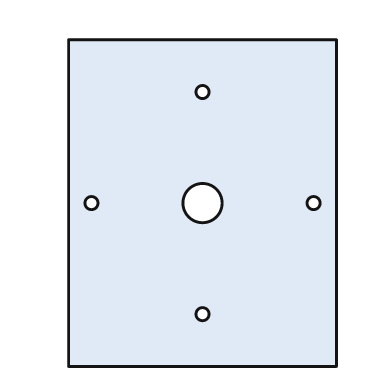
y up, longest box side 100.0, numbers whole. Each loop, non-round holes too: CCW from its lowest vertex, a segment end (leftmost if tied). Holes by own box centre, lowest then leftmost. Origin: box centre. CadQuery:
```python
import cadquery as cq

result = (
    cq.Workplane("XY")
    .moveTo(-41.0, -50.0)
    .lineTo(41.0, -50.0)
    .lineTo(41.0, 50.0)
    .lineTo(-41.0, 50.0)
    .close()
    .moveTo(0.0, -34.0)
    .circle(2.0)
    .moveTo(-34.0, 0.0)
    .circle(2.0)
    .moveTo(0.0, 0.0)
    .circle(6.0)
    .moveTo(34.0, 0.0)
    .circle(2.0)
    .moveTo(0.0, 34.0)
    .circle(2.0)
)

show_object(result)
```